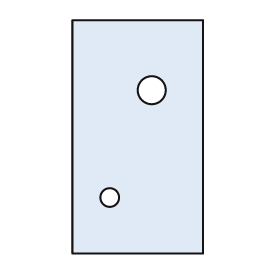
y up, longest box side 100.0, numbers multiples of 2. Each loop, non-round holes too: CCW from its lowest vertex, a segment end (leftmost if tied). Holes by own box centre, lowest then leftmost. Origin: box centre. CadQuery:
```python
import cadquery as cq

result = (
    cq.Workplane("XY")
    .moveTo(-28.0, -50.0)
    .lineTo(28.0, -50.0)
    .lineTo(28.0, 50.0)
    .lineTo(-28.0, 50.0)
    .close()
    .moveTo(-12.0, -26.0)
    .circle(4.0)
    .moveTo(6.0, 20.0)
    .circle(6.0)
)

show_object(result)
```